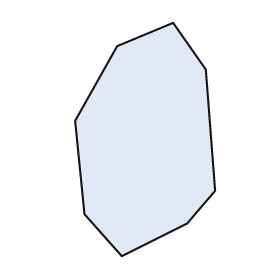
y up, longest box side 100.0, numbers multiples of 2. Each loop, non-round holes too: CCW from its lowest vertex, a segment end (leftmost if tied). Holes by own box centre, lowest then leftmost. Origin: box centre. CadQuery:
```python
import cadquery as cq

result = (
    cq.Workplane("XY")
    .moveTo(-10.0, -50.0)
    .lineTo(18.0, -36.0)
    .lineTo(30.0, -22.0)
    .lineTo(26.0, 30.0)
    .lineTo(12.0, 50.0)
    .lineTo(-12.0, 40.0)
    .lineTo(-30.0, 8.0)
    .lineTo(-26.0, -32.0)
    .close()
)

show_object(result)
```